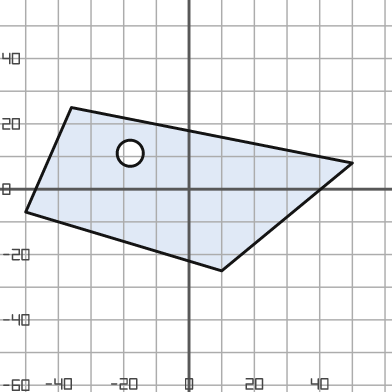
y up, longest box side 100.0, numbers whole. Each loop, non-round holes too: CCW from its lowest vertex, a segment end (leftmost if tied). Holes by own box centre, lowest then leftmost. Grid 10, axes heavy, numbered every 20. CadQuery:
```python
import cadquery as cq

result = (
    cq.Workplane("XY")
    .moveTo(10.0, -25.0)
    .lineTo(50.0, 8.0)
    .lineTo(-36.0, 25.0)
    .lineTo(-50.0, -7.0)
    .close()
    .moveTo(-18.0, 11.0)
    .circle(4.0)
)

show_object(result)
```